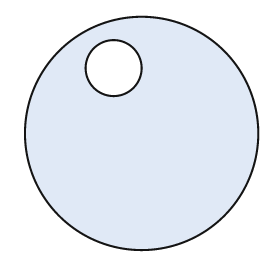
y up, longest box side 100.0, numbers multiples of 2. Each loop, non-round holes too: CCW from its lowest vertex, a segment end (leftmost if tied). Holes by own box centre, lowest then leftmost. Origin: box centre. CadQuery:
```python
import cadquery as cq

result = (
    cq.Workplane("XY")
    .moveTo(0.0, 0.0)
    .circle(50.0)
    .moveTo(-12.0, 28.0)
    .circle(12.0)
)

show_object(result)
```